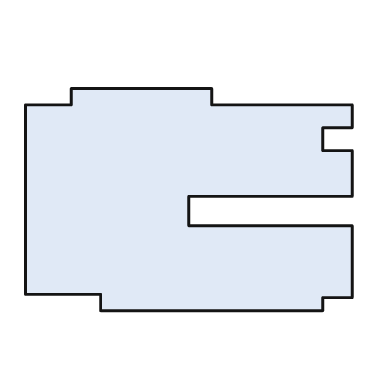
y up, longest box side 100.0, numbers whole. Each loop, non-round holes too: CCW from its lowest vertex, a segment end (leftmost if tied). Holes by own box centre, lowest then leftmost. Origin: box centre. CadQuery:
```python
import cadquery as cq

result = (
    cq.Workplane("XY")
    .moveTo(-27.0, -34.0)
    .lineTo(41.0, -34.0)
    .lineTo(41.0, -30.0)
    .lineTo(50.0, -30.0)
    .lineTo(50.0, -8.0)
    .lineTo(0.0, -8.0)
    .lineTo(0.0, 1.0)
    .lineTo(50.0, 1.0)
    .lineTo(50.0, 15.0)
    .lineTo(41.0, 15.0)
    .lineTo(41.0, 22.0)
    .lineTo(50.0, 22.0)
    .lineTo(50.0, 29.0)
    .lineTo(7.0, 29.0)
    .lineTo(7.0, 34.0)
    .lineTo(-36.0, 34.0)
    .lineTo(-36.0, 29.0)
    .lineTo(-50.0, 29.0)
    .lineTo(-50.0, -29.0)
    .lineTo(-27.0, -29.0)
    .close()
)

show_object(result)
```